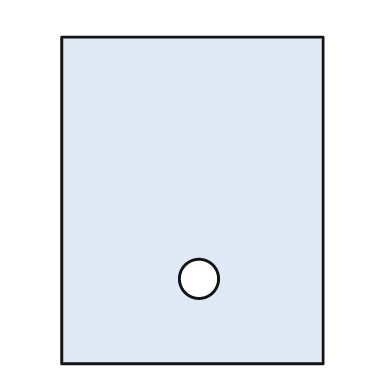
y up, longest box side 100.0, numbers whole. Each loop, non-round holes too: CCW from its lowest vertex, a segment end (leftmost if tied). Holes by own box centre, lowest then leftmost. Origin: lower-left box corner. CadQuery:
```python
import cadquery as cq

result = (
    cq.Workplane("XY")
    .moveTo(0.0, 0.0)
    .lineTo(80.0, 0.0)
    .lineTo(80.0, 100.0)
    .lineTo(0.0, 100.0)
    .close()
    .moveTo(42.0, 26.0)
    .circle(6.0)
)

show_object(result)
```